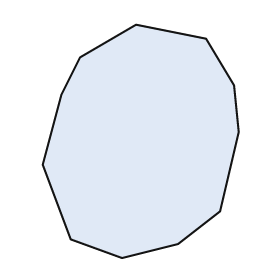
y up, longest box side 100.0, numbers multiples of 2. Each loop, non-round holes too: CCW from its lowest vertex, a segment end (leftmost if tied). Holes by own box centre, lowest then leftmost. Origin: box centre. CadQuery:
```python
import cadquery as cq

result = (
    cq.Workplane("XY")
    .moveTo(-8.0, -50.0)
    .lineTo(16.0, -44.0)
    .lineTo(34.0, -30.0)
    .lineTo(42.0, 4.0)
    .lineTo(40.0, 24.0)
    .lineTo(28.0, 44.0)
    .lineTo(-2.0, 50.0)
    .lineTo(-26.0, 36.0)
    .lineTo(-34.0, 20.0)
    .lineTo(-42.0, -10.0)
    .lineTo(-30.0, -42.0)
    .close()
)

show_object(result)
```